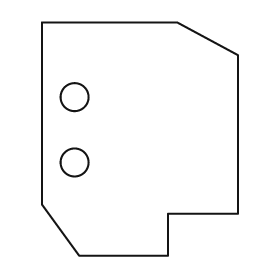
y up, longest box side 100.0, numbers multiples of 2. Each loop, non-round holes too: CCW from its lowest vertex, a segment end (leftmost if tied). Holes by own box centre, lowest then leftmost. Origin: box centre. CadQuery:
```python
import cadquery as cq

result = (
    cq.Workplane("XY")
    .moveTo(-26.0, -50.0)
    .lineTo(12.0, -50.0)
    .lineTo(12.0, -32.0)
    .lineTo(42.0, -32.0)
    .lineTo(42.0, 36.0)
    .lineTo(16.0, 50.0)
    .lineTo(-42.0, 50.0)
    .lineTo(-42.0, -28.0)
    .close()
    .moveTo(-28.0, -10.0)
    .circle(6.0)
    .moveTo(-28.0, 18.0)
    .circle(6.0)
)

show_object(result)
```